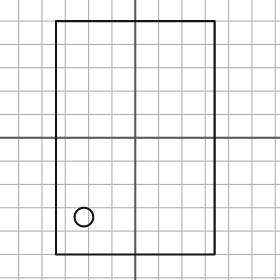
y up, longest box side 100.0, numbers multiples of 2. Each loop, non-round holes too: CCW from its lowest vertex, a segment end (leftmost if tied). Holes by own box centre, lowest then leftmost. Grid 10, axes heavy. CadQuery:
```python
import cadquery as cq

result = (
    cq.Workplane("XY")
    .moveTo(-34.0, -50.0)
    .lineTo(34.0, -50.0)
    .lineTo(34.0, 50.0)
    .lineTo(-34.0, 50.0)
    .close()
    .moveTo(-22.0, -34.0)
    .circle(4.0)
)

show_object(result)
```